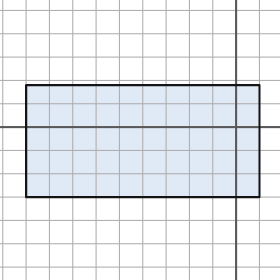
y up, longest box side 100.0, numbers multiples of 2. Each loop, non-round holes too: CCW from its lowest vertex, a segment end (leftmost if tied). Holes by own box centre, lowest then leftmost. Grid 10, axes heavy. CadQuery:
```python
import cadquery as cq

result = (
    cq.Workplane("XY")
    .moveTo(-90.0, -30.0)
    .lineTo(10.0, -30.0)
    .lineTo(10.0, 18.0)
    .lineTo(-90.0, 18.0)
    .close()
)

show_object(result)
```